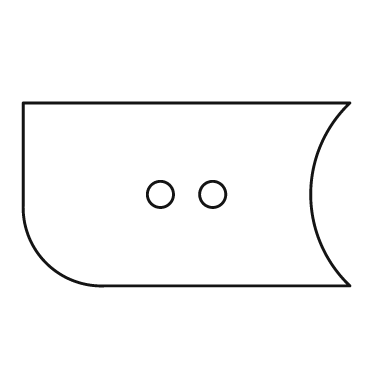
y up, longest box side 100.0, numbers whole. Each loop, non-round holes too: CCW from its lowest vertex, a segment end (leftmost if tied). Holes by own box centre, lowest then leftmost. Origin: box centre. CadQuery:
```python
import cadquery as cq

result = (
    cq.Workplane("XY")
    .moveTo(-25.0, -28.0)
    .lineTo(50.0, -28.0)
    .threePointArc((38.0, 0.0), (50.0, 28.0))
    .lineTo(-50.0, 28.0)
    .lineTo(-50.0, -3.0)
    .threePointArc((-43.0, -21.0), (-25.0, -28.0))
    .close()
    .moveTo(-8.0, 0.0)
    .circle(4.0)
    .moveTo(8.0, 0.0)
    .circle(4.0)
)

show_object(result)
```